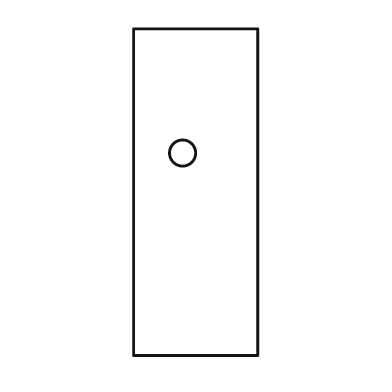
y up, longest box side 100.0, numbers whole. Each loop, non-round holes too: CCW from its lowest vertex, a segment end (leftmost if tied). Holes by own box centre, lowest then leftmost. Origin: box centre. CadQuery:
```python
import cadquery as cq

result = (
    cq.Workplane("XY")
    .moveTo(-19.0, -50.0)
    .lineTo(19.0, -50.0)
    .lineTo(19.0, 50.0)
    .lineTo(-19.0, 50.0)
    .close()
    .moveTo(-4.0, 12.0)
    .circle(4.0)
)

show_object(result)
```